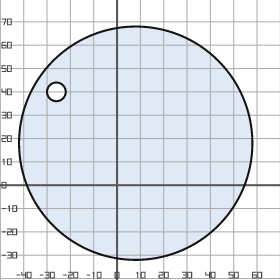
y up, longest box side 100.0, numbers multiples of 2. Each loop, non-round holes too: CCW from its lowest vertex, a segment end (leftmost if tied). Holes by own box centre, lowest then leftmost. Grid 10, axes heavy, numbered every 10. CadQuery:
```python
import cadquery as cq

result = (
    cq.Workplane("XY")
    .moveTo(8.0, 18.0)
    .circle(50.0)
    .moveTo(-26.0, 40.0)
    .circle(4.0)
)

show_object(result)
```